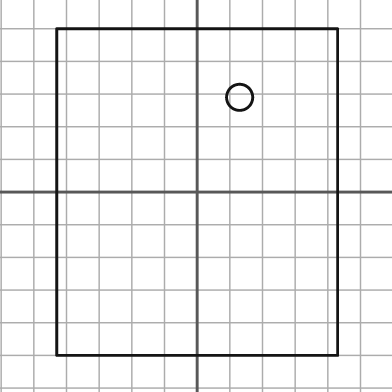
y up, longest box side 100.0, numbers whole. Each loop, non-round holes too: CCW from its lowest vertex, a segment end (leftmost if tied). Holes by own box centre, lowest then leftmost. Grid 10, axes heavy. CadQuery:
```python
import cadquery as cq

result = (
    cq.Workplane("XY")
    .moveTo(-43.0, -50.0)
    .lineTo(43.0, -50.0)
    .lineTo(43.0, 50.0)
    .lineTo(-43.0, 50.0)
    .close()
    .moveTo(13.0, 29.0)
    .circle(4.0)
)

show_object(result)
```